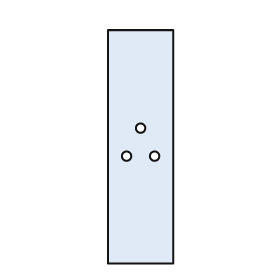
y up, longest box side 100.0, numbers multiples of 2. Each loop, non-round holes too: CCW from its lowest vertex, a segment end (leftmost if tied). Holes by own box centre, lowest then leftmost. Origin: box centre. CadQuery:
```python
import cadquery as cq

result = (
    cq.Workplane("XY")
    .moveTo(-14.0, -50.0)
    .lineTo(14.0, -50.0)
    .lineTo(14.0, 50.0)
    .lineTo(-14.0, 50.0)
    .close()
    .moveTo(-6.0, -4.0)
    .circle(2.0)
    .moveTo(6.0, -4.0)
    .circle(2.0)
    .moveTo(0.0, 8.0)
    .circle(2.0)
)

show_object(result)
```